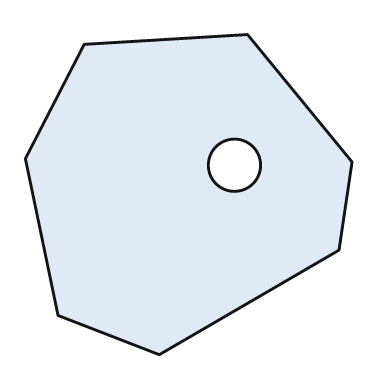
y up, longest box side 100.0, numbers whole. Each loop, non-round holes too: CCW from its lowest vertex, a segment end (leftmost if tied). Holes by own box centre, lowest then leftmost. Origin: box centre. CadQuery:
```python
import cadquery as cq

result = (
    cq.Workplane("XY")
    .moveTo(-9.0, -49.0)
    .lineTo(46.0, -17.0)
    .lineTo(50.0, 10.0)
    .lineTo(18.0, 49.0)
    .lineTo(-32.0, 46.0)
    .lineTo(-50.0, 11.0)
    .lineTo(-40.0, -37.0)
    .close()
    .moveTo(14.0, 9.0)
    .circle(8.0)
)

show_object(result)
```